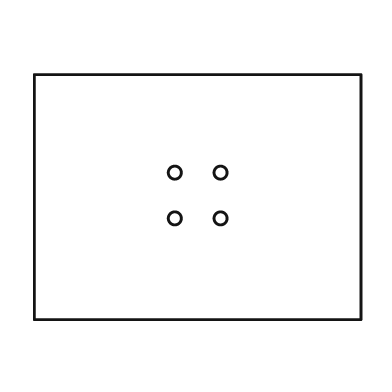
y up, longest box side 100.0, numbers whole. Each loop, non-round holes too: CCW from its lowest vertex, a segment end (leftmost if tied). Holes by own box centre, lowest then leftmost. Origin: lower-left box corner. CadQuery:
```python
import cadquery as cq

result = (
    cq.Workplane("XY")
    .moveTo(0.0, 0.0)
    .lineTo(100.0, 0.0)
    .lineTo(100.0, 75.0)
    .lineTo(0.0, 75.0)
    .close()
    .moveTo(43.0, 31.0)
    .circle(2.0)
    .moveTo(57.0, 31.0)
    .circle(2.0)
    .moveTo(43.0, 45.0)
    .circle(2.0)
    .moveTo(57.0, 45.0)
    .circle(2.0)
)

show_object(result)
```